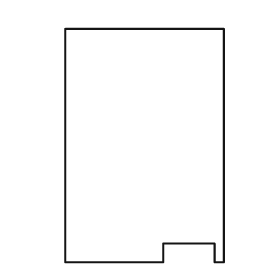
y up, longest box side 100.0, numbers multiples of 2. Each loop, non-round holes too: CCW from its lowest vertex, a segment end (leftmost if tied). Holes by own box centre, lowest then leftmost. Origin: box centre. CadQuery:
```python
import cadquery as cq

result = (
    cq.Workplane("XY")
    .moveTo(-34.0, -50.0)
    .lineTo(8.0, -50.0)
    .lineTo(8.0, -42.0)
    .lineTo(30.0, -42.0)
    .lineTo(30.0, -50.0)
    .lineTo(34.0, -50.0)
    .lineTo(34.0, 50.0)
    .lineTo(-34.0, 50.0)
    .close()
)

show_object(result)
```